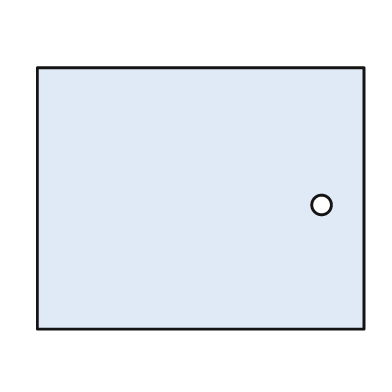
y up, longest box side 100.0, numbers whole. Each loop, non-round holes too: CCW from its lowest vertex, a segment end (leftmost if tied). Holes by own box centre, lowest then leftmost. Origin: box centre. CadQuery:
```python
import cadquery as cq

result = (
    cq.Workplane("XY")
    .moveTo(-50.0, -40.0)
    .lineTo(50.0, -40.0)
    .lineTo(50.0, 40.0)
    .lineTo(-50.0, 40.0)
    .close()
    .moveTo(37.0, -2.0)
    .circle(3.0)
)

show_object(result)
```